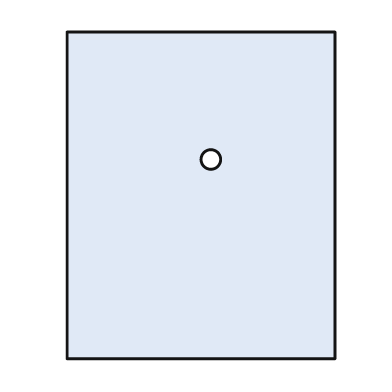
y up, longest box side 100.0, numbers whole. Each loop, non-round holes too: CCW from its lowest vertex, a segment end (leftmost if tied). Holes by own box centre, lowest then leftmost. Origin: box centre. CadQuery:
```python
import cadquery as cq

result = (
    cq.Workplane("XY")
    .moveTo(-41.0, -50.0)
    .lineTo(41.0, -50.0)
    .lineTo(41.0, 50.0)
    .lineTo(-41.0, 50.0)
    .close()
    .moveTo(3.0, 11.0)
    .circle(3.0)
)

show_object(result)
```